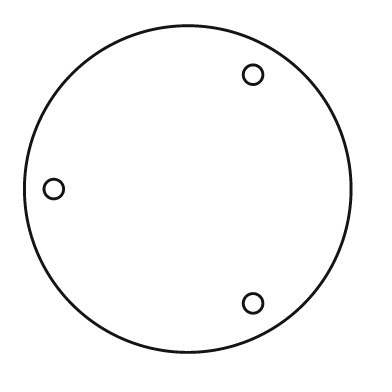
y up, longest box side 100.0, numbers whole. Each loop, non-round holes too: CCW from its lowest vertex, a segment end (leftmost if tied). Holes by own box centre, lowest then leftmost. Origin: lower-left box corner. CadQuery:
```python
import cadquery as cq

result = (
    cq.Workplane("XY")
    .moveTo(50.0, 50.0)
    .circle(50.0)
    .moveTo(70.0, 15.0)
    .circle(3.0)
    .moveTo(9.0, 50.0)
    .circle(3.0)
    .moveTo(70.0, 85.0)
    .circle(3.0)
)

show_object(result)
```